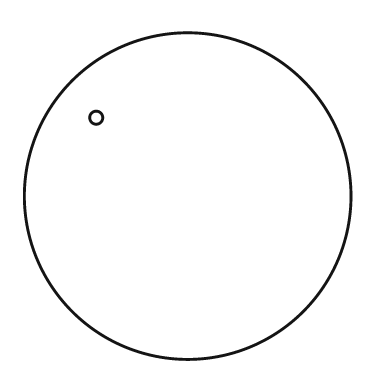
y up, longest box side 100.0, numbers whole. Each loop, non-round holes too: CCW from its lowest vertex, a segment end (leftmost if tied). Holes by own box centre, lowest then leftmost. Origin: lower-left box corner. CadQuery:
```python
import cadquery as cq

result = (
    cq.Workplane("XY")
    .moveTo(50.0, 50.0)
    .circle(50.0)
    .moveTo(22.0, 74.0)
    .circle(2.0)
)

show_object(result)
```